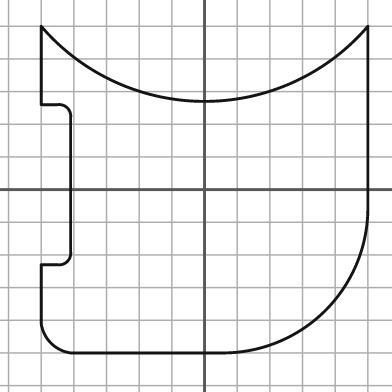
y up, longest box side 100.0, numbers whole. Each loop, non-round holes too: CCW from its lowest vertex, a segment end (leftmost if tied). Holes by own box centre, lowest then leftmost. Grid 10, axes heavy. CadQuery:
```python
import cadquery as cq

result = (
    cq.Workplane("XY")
    .moveTo(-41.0, -50.0)
    .lineTo(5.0, -50.0)
    .threePointArc((37.0, -37.0), (50.0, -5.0))
    .lineTo(50.0, 50.0)
    .threePointArc((0.0, 27.0), (-50.0, 50.0))
    .lineTo(-50.0, 26.0)
    .lineTo(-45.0, 26.0)
    .threePointArc((-42.0, 25.0), (-41.0, 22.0))
    .lineTo(-41.0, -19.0)
    .threePointArc((-42.0, -22.0), (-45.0, -23.0))
    .lineTo(-50.0, -23.0)
    .lineTo(-50.0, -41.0)
    .threePointArc((-47.0, -47.0), (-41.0, -50.0))
    .close()
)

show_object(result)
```